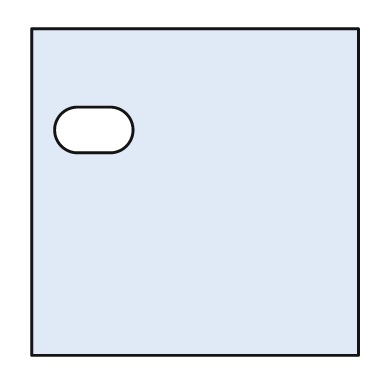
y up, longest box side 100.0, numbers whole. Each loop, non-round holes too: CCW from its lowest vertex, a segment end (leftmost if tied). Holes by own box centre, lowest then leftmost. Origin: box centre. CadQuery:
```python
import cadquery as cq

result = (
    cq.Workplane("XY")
    .moveTo(-50.0, -50.0)
    .lineTo(50.0, -50.0)
    .lineTo(50.0, 50.0)
    .lineTo(-50.0, 50.0)
    .close()
    .moveTo(-36.0, 12.0)
    .lineTo(-26.0, 12.0)
    .threePointArc((-19.0, 19.0), (-26.0, 26.0))
    .lineTo(-36.0, 26.0)
    .threePointArc((-43.0, 19.0), (-36.0, 12.0))
    .close()
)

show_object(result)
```